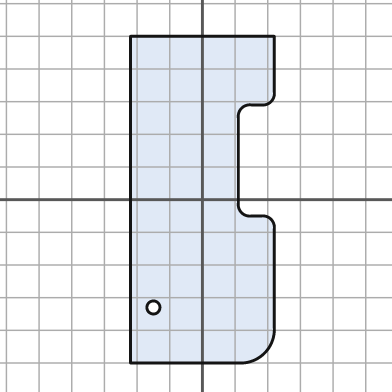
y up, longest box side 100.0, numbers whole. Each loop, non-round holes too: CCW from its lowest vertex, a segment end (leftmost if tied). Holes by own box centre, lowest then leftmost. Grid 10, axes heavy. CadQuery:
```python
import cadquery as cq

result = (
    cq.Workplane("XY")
    .moveTo(-22.0, -50.0)
    .lineTo(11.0, -50.0)
    .threePointArc((19.0, -47.0), (22.0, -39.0))
    .lineTo(22.0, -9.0)
    .threePointArc((21.0, -6.0), (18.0, -5.0))
    .lineTo(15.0, -5.0)
    .threePointArc((12.0, -4.0), (11.0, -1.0))
    .lineTo(11.0, 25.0)
    .threePointArc((12.0, 28.0), (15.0, 29.0))
    .lineTo(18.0, 29.0)
    .threePointArc((21.0, 30.0), (22.0, 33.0))
    .lineTo(22.0, 50.0)
    .lineTo(-22.0, 50.0)
    .close()
    .moveTo(-15.0, -33.0)
    .circle(2.0)
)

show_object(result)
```